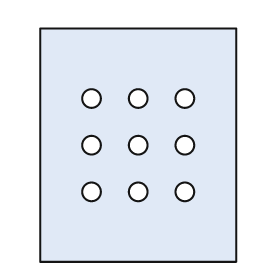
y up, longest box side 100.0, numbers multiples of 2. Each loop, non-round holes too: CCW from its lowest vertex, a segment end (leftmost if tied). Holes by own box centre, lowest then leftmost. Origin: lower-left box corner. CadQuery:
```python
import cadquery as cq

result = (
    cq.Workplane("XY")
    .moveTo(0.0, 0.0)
    .lineTo(84.0, 0.0)
    .lineTo(84.0, 100.0)
    .lineTo(0.0, 100.0)
    .close()
    .moveTo(22.0, 30.0)
    .circle(4.0)
    .moveTo(42.0, 30.0)
    .circle(4.0)
    .moveTo(62.0, 30.0)
    .circle(4.0)
    .moveTo(22.0, 50.0)
    .circle(4.0)
    .moveTo(42.0, 50.0)
    .circle(4.0)
    .moveTo(62.0, 50.0)
    .circle(4.0)
    .moveTo(22.0, 70.0)
    .circle(4.0)
    .moveTo(42.0, 70.0)
    .circle(4.0)
    .moveTo(62.0, 70.0)
    .circle(4.0)
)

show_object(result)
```